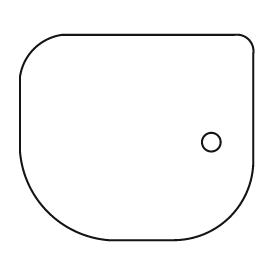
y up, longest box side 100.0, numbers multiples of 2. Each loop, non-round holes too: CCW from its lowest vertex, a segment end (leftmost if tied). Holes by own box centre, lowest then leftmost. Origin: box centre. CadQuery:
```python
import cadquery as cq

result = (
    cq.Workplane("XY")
    .moveTo(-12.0, -44.0)
    .lineTo(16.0, -44.0)
    .threePointArc((40.0, -34.0), (50.0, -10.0))
    .lineTo(50.0, 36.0)
    .threePointArc((48.0, 42.0), (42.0, 44.0))
    .lineTo(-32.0, 44.0)
    .threePointArc((-44.0, 38.0), (-50.0, 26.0))
    .lineTo(-50.0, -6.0)
    .threePointArc((-38.0, -32.0), (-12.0, -44.0))
    .close()
    .moveTo(32.0, -2.0)
    .circle(4.0)
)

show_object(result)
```